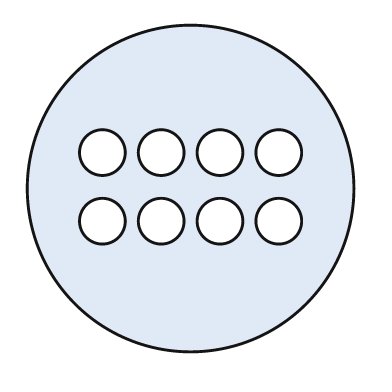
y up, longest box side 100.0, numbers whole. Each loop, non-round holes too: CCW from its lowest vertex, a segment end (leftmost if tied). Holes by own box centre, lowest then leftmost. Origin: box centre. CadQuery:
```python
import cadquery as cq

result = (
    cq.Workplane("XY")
    .moveTo(0.0, 0.0)
    .circle(50.0)
    .moveTo(-27.0, -10.0)
    .circle(7.0)
    .moveTo(-9.0, -10.0)
    .circle(7.0)
    .moveTo(9.0, -10.0)
    .circle(7.0)
    .moveTo(27.0, -10.0)
    .circle(7.0)
    .moveTo(-27.0, 11.0)
    .circle(7.0)
    .moveTo(-9.0, 11.0)
    .circle(7.0)
    .moveTo(9.0, 11.0)
    .circle(7.0)
    .moveTo(27.0, 11.0)
    .circle(7.0)
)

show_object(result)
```